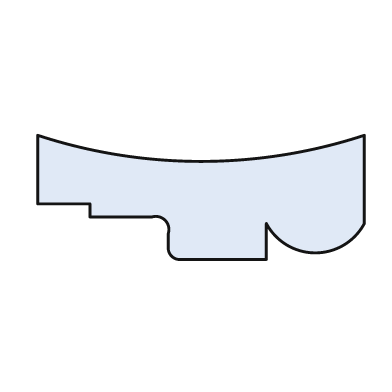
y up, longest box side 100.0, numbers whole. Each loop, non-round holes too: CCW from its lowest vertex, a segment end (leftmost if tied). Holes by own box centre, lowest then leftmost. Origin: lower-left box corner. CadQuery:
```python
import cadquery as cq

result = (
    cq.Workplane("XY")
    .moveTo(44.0, 0.0)
    .lineTo(70.0, 0.0)
    .lineTo(70.0, 11.0)
    .threePointArc((85.0, 2.0), (100.0, 11.0))
    .lineTo(100.0, 38.0)
    .threePointArc((50.0, 30.0), (0.0, 38.0))
    .lineTo(0.0, 17.0)
    .lineTo(16.0, 17.0)
    .lineTo(16.0, 13.0)
    .lineTo(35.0, 13.0)
    .threePointArc((39.0, 12.0), (40.0, 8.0))
    .lineTo(40.0, 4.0)
    .threePointArc((41.0, 1.0), (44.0, 0.0))
    .close()
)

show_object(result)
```